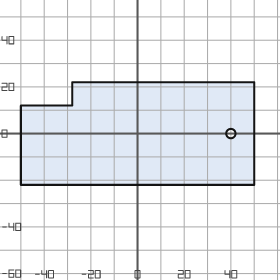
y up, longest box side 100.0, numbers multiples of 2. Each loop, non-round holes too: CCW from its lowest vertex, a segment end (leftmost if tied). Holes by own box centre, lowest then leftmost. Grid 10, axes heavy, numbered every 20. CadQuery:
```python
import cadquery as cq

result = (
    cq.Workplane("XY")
    .moveTo(-50.0, -22.0)
    .lineTo(50.0, -22.0)
    .lineTo(50.0, 22.0)
    .lineTo(-28.0, 22.0)
    .lineTo(-28.0, 12.0)
    .lineTo(-50.0, 12.0)
    .close()
    .moveTo(40.0, 0.0)
    .circle(2.0)
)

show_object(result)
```